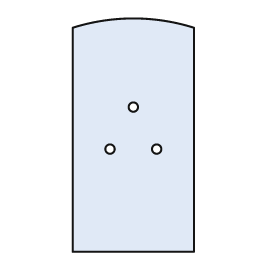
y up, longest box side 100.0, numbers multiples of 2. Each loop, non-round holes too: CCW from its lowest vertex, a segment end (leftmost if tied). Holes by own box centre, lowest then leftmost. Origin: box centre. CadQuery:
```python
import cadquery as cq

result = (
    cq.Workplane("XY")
    .moveTo(-26.0, -50.0)
    .lineTo(26.0, -50.0)
    .lineTo(26.0, 46.0)
    .threePointArc((0.0, 50.0), (-26.0, 46.0))
    .close()
    .moveTo(-10.0, -6.0)
    .circle(2.0)
    .moveTo(10.0, -6.0)
    .circle(2.0)
    .moveTo(0.0, 12.0)
    .circle(2.0)
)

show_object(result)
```